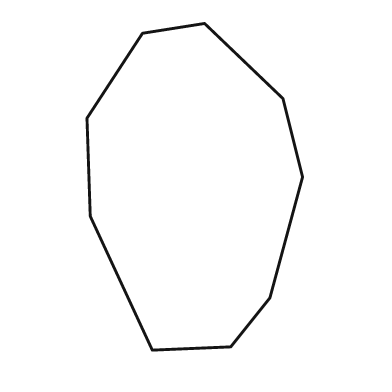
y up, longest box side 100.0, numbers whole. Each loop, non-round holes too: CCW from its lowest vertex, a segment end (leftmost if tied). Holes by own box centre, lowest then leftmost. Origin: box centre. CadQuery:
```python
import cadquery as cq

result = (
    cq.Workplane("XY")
    .moveTo(-13.0, -50.0)
    .lineTo(11.0, -49.0)
    .lineTo(23.0, -34.0)
    .lineTo(33.0, 3.0)
    .lineTo(27.0, 27.0)
    .lineTo(3.0, 50.0)
    .lineTo(-16.0, 47.0)
    .lineTo(-33.0, 21.0)
    .lineTo(-32.0, -9.0)
    .close()
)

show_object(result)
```